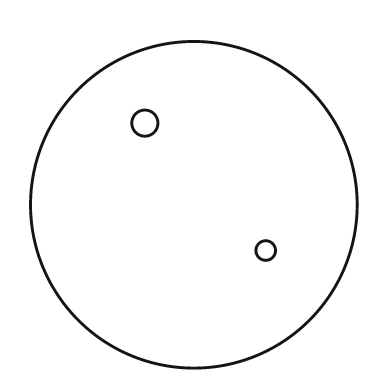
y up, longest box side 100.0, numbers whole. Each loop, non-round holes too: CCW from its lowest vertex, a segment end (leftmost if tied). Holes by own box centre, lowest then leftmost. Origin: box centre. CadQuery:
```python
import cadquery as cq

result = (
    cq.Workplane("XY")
    .moveTo(0.0, 0.0)
    .circle(50.0)
    .moveTo(22.0, -14.0)
    .circle(3.0)
    .moveTo(-15.0, 25.0)
    .circle(4.0)
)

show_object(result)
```